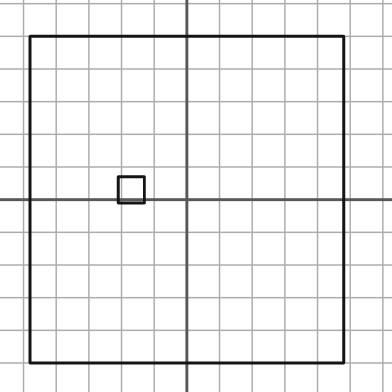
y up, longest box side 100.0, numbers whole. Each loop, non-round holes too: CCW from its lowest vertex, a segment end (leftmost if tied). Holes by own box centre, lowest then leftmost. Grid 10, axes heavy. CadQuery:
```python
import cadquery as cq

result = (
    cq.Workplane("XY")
    .moveTo(-48.0, -50.0)
    .lineTo(48.0, -50.0)
    .lineTo(48.0, 50.0)
    .lineTo(-48.0, 50.0)
    .close()
    .moveTo(-21.0, -1.0)
    .lineTo(-13.0, -1.0)
    .lineTo(-13.0, 7.0)
    .lineTo(-21.0, 7.0)
    .close()
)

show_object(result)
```